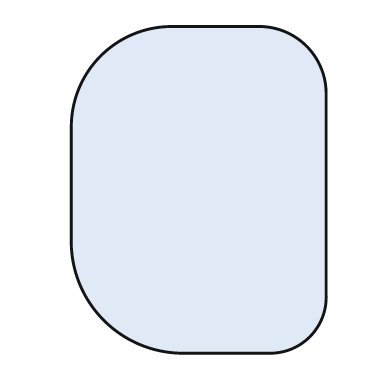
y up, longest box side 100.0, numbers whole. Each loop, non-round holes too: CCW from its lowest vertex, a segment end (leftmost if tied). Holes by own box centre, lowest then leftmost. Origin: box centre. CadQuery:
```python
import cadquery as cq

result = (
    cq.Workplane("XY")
    .moveTo(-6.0, -50.0)
    .lineTo(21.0, -50.0)
    .threePointArc((34.0, -45.0), (39.0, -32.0))
    .lineTo(39.0, 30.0)
    .threePointArc((33.0, 44.0), (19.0, 50.0))
    .lineTo(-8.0, 50.0)
    .threePointArc((-30.0, 41.0), (-39.0, 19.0))
    .lineTo(-39.0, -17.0)
    .threePointArc((-29.0, -40.0), (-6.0, -50.0))
    .close()
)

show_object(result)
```